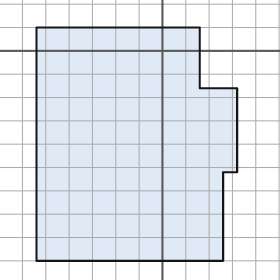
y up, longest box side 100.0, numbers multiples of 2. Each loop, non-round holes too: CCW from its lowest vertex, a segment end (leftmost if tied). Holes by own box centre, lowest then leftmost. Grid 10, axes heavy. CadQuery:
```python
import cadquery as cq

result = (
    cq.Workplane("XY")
    .moveTo(-54.0, -90.0)
    .lineTo(26.0, -90.0)
    .lineTo(26.0, -52.0)
    .lineTo(32.0, -52.0)
    .lineTo(32.0, -16.0)
    .lineTo(16.0, -16.0)
    .lineTo(16.0, 10.0)
    .lineTo(-54.0, 10.0)
    .close()
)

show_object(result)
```